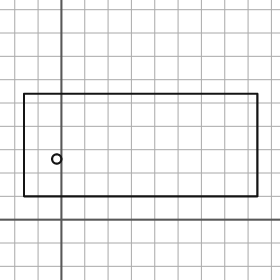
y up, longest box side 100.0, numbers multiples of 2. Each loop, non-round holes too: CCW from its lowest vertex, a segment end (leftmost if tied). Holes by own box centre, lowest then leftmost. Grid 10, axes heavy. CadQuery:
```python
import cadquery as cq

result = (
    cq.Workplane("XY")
    .moveTo(-16.0, 10.0)
    .lineTo(84.0, 10.0)
    .lineTo(84.0, 54.0)
    .lineTo(-16.0, 54.0)
    .close()
    .moveTo(-2.0, 26.0)
    .circle(2.0)
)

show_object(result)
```